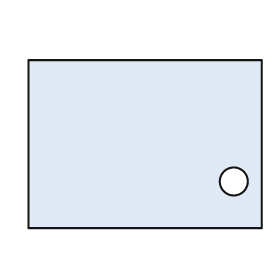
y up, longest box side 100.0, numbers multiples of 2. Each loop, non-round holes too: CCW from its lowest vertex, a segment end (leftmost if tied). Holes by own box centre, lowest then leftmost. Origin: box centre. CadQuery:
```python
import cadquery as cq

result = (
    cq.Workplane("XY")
    .moveTo(-50.0, -36.0)
    .lineTo(50.0, -36.0)
    .lineTo(50.0, 36.0)
    .lineTo(-50.0, 36.0)
    .close()
    .moveTo(38.0, -16.0)
    .circle(6.0)
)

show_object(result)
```